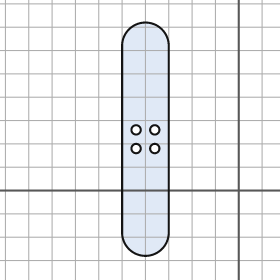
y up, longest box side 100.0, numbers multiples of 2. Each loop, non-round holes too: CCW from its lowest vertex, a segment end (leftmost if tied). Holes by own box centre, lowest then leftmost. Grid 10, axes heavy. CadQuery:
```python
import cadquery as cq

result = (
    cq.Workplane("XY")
    .moveTo(-50.0, -18.0)
    .threePointArc((-40.0, -28.0), (-30.0, -18.0))
    .lineTo(-30.0, 62.0)
    .threePointArc((-40.0, 72.0), (-50.0, 62.0))
    .close()
    .moveTo(-44.0, 18.0)
    .circle(2.0)
    .moveTo(-36.0, 18.0)
    .circle(2.0)
    .moveTo(-44.0, 26.0)
    .circle(2.0)
    .moveTo(-36.0, 26.0)
    .circle(2.0)
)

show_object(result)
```